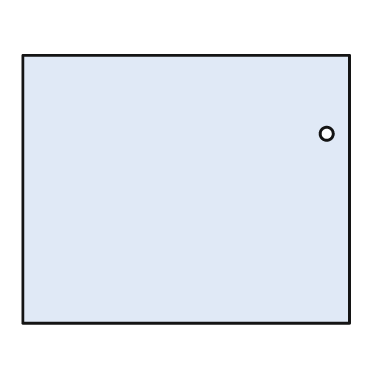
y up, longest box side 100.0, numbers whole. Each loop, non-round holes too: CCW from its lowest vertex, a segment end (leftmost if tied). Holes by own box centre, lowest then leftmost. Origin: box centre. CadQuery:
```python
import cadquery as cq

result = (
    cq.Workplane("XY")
    .moveTo(-50.0, -41.0)
    .lineTo(50.0, -41.0)
    .lineTo(50.0, 41.0)
    .lineTo(-50.0, 41.0)
    .close()
    .moveTo(43.0, 17.0)
    .circle(2.0)
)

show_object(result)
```